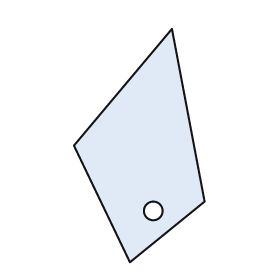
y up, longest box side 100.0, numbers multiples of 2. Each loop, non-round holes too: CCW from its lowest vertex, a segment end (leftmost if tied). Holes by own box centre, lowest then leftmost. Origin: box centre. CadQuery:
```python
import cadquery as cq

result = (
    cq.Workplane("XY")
    .moveTo(-4.0, -50.0)
    .lineTo(28.0, -24.0)
    .lineTo(14.0, 50.0)
    .lineTo(-28.0, 0.0)
    .close()
    .moveTo(6.0, -28.0)
    .circle(4.0)
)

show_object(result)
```